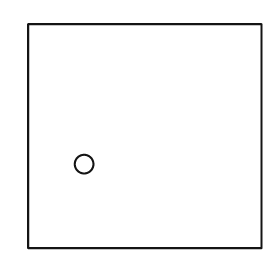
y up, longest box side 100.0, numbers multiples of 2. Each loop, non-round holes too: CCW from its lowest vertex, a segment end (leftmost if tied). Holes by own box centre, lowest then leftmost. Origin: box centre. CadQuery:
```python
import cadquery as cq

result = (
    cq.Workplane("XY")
    .moveTo(-50.0, -48.0)
    .lineTo(50.0, -48.0)
    .lineTo(50.0, 48.0)
    .lineTo(-50.0, 48.0)
    .close()
    .moveTo(-26.0, -12.0)
    .circle(4.0)
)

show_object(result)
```